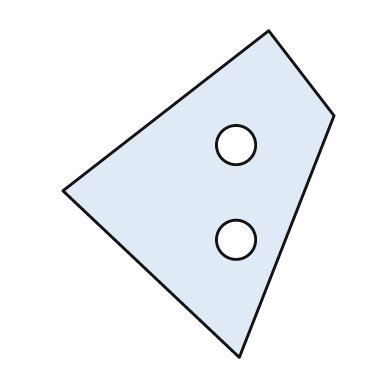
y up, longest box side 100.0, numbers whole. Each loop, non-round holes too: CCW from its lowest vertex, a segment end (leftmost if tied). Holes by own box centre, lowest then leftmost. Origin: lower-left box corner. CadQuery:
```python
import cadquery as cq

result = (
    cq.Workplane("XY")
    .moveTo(54.0, 0.0)
    .lineTo(83.0, 74.0)
    .lineTo(63.0, 100.0)
    .lineTo(0.0, 51.0)
    .close()
    .moveTo(53.0, 36.0)
    .circle(6.0)
    .moveTo(53.0, 65.0)
    .circle(6.0)
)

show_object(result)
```